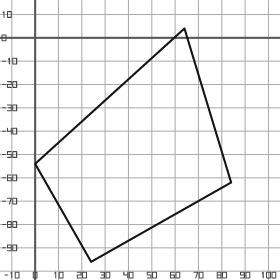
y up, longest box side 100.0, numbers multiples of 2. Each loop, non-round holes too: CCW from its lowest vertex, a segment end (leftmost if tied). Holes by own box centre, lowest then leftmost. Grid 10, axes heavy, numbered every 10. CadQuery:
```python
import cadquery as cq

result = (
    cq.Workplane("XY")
    .moveTo(24.0, -96.0)
    .lineTo(84.0, -62.0)
    .lineTo(64.0, 4.0)
    .lineTo(0.0, -54.0)
    .close()
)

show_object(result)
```